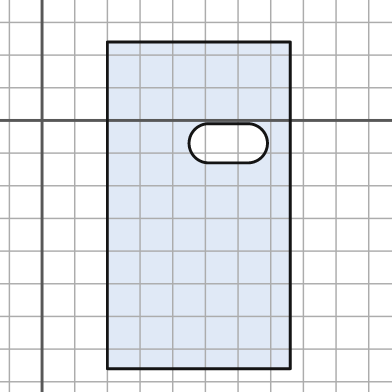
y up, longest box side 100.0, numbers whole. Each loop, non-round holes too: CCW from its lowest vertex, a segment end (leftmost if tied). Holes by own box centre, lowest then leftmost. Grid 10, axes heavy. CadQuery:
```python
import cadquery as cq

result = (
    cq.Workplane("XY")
    .moveTo(20.0, -76.0)
    .lineTo(76.0, -76.0)
    .lineTo(76.0, 24.0)
    .lineTo(20.0, 24.0)
    .close()
    .moveTo(51.0, -13.0)
    .lineTo(63.0, -13.0)
    .threePointArc((69.0, -7.0), (63.0, -1.0))
    .lineTo(51.0, -1.0)
    .threePointArc((45.0, -7.0), (51.0, -13.0))
    .close()
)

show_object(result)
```